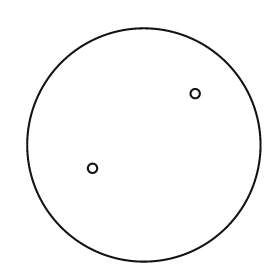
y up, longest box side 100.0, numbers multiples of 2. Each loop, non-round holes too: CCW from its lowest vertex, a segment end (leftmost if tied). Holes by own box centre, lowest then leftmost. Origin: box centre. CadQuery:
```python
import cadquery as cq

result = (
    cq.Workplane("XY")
    .moveTo(0.0, 0.0)
    .circle(50.0)
    .moveTo(-22.0, -10.0)
    .circle(2.0)
    .moveTo(22.0, 22.0)
    .circle(2.0)
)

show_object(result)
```